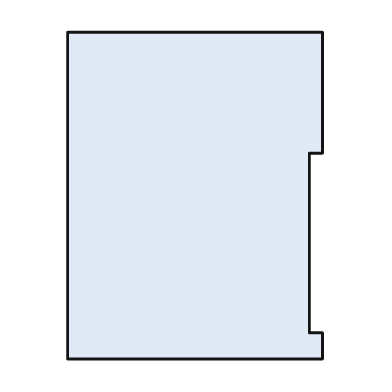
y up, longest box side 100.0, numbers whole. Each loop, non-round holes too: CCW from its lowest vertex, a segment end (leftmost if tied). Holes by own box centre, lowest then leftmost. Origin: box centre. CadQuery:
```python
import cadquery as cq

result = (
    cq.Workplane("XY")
    .moveTo(-39.0, -50.0)
    .lineTo(39.0, -50.0)
    .lineTo(39.0, -42.0)
    .lineTo(35.0, -42.0)
    .lineTo(35.0, 13.0)
    .lineTo(39.0, 13.0)
    .lineTo(39.0, 50.0)
    .lineTo(-39.0, 50.0)
    .close()
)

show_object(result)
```